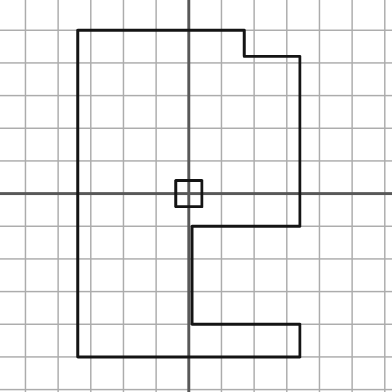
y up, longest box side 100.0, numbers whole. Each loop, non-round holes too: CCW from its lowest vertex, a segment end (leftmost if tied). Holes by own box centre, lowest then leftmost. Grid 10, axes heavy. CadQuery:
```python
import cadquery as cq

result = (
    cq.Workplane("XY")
    .moveTo(-34.0, -50.0)
    .lineTo(34.0, -50.0)
    .lineTo(34.0, -40.0)
    .lineTo(1.0, -40.0)
    .lineTo(1.0, -10.0)
    .lineTo(34.0, -10.0)
    .lineTo(34.0, 42.0)
    .lineTo(17.0, 42.0)
    .lineTo(17.0, 50.0)
    .lineTo(-34.0, 50.0)
    .close()
    .moveTo(-4.0, -4.0)
    .lineTo(4.0, -4.0)
    .lineTo(4.0, 4.0)
    .lineTo(-4.0, 4.0)
    .close()
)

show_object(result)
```